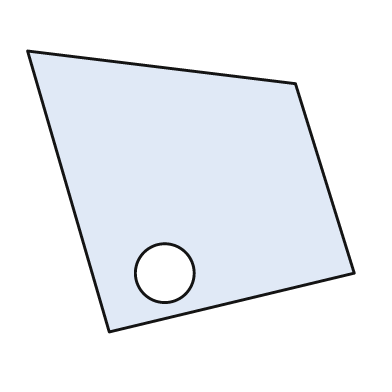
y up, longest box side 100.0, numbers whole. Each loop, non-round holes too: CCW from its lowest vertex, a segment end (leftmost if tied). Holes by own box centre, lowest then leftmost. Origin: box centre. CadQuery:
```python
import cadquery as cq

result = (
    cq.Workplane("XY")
    .moveTo(-25.0, -43.0)
    .lineTo(50.0, -25.0)
    .lineTo(32.0, 33.0)
    .lineTo(-50.0, 43.0)
    .close()
    .moveTo(-8.0, -25.0)
    .circle(9.0)
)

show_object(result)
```